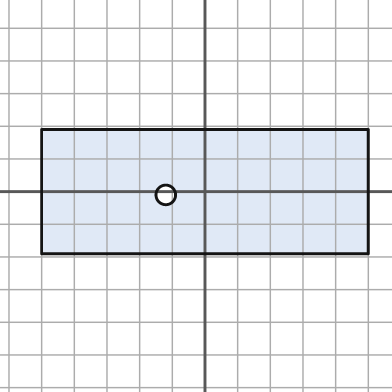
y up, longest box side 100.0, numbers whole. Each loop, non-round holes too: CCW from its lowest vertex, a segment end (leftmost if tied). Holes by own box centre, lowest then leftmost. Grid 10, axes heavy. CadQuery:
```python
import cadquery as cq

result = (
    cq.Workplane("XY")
    .moveTo(-50.0, -19.0)
    .lineTo(50.0, -19.0)
    .lineTo(50.0, 19.0)
    .lineTo(-50.0, 19.0)
    .close()
    .moveTo(-12.0, -1.0)
    .circle(3.0)
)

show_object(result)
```